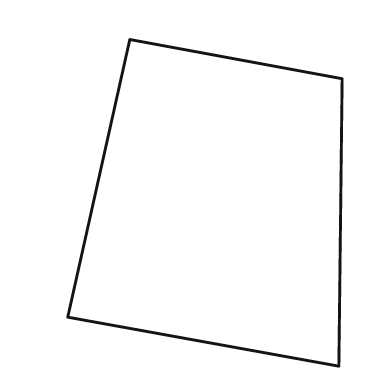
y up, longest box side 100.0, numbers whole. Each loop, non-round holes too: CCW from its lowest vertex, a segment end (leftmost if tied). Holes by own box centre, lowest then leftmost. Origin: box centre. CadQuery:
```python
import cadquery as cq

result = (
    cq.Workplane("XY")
    .moveTo(41.0, -50.0)
    .lineTo(42.0, 38.0)
    .lineTo(-23.0, 50.0)
    .lineTo(-42.0, -35.0)
    .close()
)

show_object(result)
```